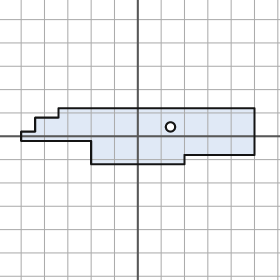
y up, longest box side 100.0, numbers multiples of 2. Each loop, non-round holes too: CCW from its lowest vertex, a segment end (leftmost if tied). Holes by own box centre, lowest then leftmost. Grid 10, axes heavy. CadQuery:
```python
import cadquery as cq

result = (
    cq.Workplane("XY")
    .moveTo(-20.0, -12.0)
    .lineTo(20.0, -12.0)
    .lineTo(20.0, -8.0)
    .lineTo(50.0, -8.0)
    .lineTo(50.0, 12.0)
    .lineTo(-34.0, 12.0)
    .lineTo(-34.0, 8.0)
    .lineTo(-44.0, 8.0)
    .lineTo(-44.0, 2.0)
    .lineTo(-50.0, 2.0)
    .lineTo(-50.0, -2.0)
    .lineTo(-20.0, -2.0)
    .close()
    .moveTo(14.0, 4.0)
    .circle(2.0)
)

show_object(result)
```